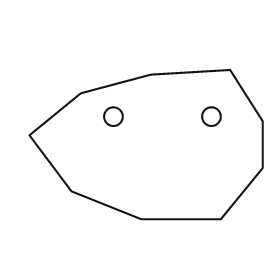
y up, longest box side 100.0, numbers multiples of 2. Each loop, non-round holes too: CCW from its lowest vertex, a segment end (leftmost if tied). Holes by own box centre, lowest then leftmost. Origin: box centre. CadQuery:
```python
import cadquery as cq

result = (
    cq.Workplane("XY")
    .moveTo(-2.0, -32.0)
    .lineTo(32.0, -32.0)
    .lineTo(50.0, -10.0)
    .lineTo(50.0, 10.0)
    .lineTo(36.0, 32.0)
    .lineTo(2.0, 30.0)
    .lineTo(-28.0, 22.0)
    .lineTo(-50.0, 4.0)
    .lineTo(-32.0, -20.0)
    .close()
    .moveTo(-14.0, 12.0)
    .circle(4.0)
    .moveTo(28.0, 12.0)
    .circle(4.0)
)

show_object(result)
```